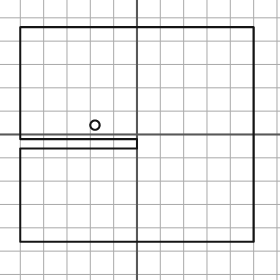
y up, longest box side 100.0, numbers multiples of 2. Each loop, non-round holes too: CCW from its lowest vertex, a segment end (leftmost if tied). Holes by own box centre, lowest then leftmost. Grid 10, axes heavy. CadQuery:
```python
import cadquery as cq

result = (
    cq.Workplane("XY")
    .moveTo(-50.0, -46.0)
    .lineTo(50.0, -46.0)
    .lineTo(50.0, 46.0)
    .lineTo(-50.0, 46.0)
    .lineTo(-50.0, -2.0)
    .lineTo(0.0, -2.0)
    .lineTo(0.0, -6.0)
    .lineTo(-50.0, -6.0)
    .close()
    .moveTo(-18.0, 4.0)
    .circle(2.0)
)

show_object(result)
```